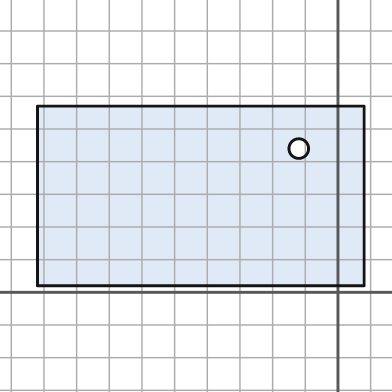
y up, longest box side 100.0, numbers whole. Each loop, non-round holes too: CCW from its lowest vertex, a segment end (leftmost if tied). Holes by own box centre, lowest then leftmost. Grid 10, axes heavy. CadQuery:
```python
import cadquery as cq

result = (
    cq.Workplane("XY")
    .moveTo(-92.0, 2.0)
    .lineTo(8.0, 2.0)
    .lineTo(8.0, 57.0)
    .lineTo(-92.0, 57.0)
    .close()
    .moveTo(-12.0, 44.0)
    .circle(3.0)
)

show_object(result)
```